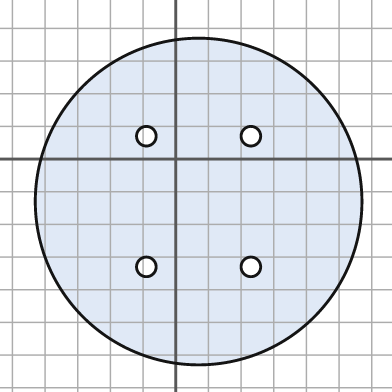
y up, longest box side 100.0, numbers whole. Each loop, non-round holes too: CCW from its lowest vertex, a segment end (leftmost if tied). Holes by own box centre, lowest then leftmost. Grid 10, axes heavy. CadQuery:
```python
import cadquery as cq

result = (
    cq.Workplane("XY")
    .moveTo(7.0, -13.0)
    .circle(50.0)
    .moveTo(-9.0, -33.0)
    .circle(3.0)
    .moveTo(23.0, -33.0)
    .circle(3.0)
    .moveTo(-9.0, 7.0)
    .circle(3.0)
    .moveTo(23.0, 7.0)
    .circle(3.0)
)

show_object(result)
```